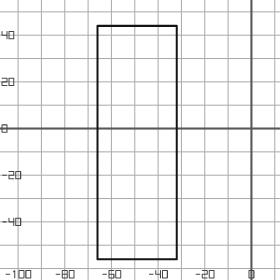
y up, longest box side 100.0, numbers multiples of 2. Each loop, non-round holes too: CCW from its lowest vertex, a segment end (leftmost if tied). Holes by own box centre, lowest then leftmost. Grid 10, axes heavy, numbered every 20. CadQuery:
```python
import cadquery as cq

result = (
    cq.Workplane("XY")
    .moveTo(-66.0, -56.0)
    .lineTo(-32.0, -56.0)
    .lineTo(-32.0, 44.0)
    .lineTo(-66.0, 44.0)
    .close()
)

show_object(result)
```